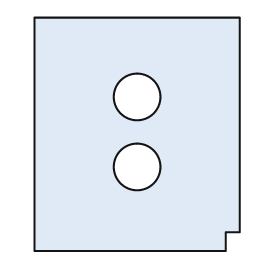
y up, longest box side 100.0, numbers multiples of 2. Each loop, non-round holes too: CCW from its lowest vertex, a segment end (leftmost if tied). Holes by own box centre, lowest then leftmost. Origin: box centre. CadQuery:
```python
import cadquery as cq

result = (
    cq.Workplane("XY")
    .moveTo(-44.0, -50.0)
    .lineTo(38.0, -50.0)
    .lineTo(38.0, -42.0)
    .lineTo(44.0, -42.0)
    .lineTo(44.0, 50.0)
    .lineTo(-44.0, 50.0)
    .close()
    .moveTo(0.0, -14.0)
    .circle(10.0)
    .moveTo(0.0, 16.0)
    .circle(10.0)
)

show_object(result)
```